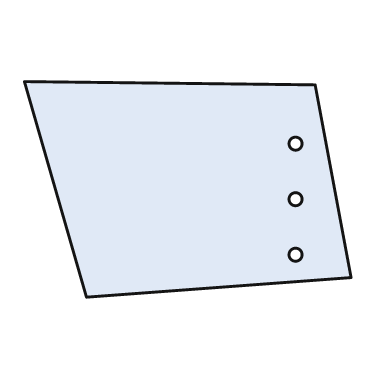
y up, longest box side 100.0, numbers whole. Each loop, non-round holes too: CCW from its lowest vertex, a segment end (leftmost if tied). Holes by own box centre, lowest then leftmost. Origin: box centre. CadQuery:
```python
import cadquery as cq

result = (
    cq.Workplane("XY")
    .moveTo(-31.0, -33.0)
    .lineTo(50.0, -27.0)
    .lineTo(39.0, 32.0)
    .lineTo(-50.0, 33.0)
    .close()
    .moveTo(33.0, -20.0)
    .circle(2.0)
    .moveTo(33.0, -3.0)
    .circle(2.0)
    .moveTo(33.0, 14.0)
    .circle(2.0)
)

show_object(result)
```